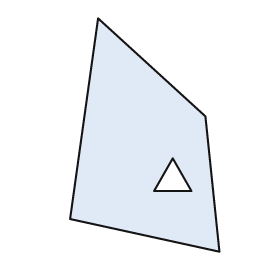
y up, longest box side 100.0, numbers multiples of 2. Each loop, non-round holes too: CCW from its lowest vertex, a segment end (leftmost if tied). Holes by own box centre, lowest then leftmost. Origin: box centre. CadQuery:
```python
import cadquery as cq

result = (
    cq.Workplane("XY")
    .moveTo(32.0, -50.0)
    .lineTo(26.0, 8.0)
    .lineTo(-20.0, 50.0)
    .lineTo(-32.0, -36.0)
    .close()
    .moveTo(4.0, -24.0)
    .lineTo(20.0, -24.0)
    .lineTo(12.0, -10.0)
    .close()
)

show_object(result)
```